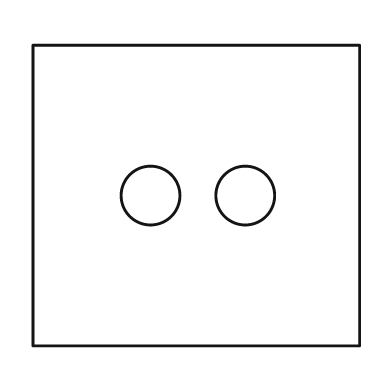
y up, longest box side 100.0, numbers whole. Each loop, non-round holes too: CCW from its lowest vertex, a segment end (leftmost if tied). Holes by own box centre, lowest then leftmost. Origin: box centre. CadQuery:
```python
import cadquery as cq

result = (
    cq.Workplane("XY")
    .moveTo(-50.0, -46.0)
    .lineTo(50.0, -46.0)
    .lineTo(50.0, 46.0)
    .lineTo(-50.0, 46.0)
    .close()
    .moveTo(-14.0, 0.0)
    .circle(9.0)
    .moveTo(15.0, 0.0)
    .circle(9.0)
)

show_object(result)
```